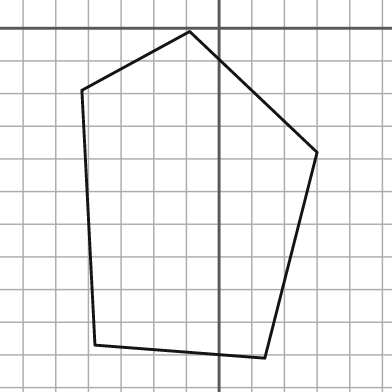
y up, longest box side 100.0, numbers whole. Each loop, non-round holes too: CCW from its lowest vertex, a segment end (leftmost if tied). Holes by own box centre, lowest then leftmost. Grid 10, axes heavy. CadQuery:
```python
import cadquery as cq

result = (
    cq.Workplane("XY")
    .moveTo(14.0, -101.0)
    .lineTo(30.0, -38.0)
    .lineTo(-9.0, -1.0)
    .lineTo(-42.0, -19.0)
    .lineTo(-38.0, -97.0)
    .close()
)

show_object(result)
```